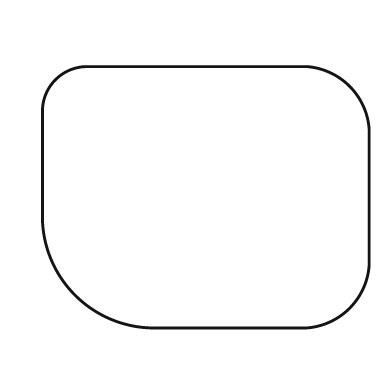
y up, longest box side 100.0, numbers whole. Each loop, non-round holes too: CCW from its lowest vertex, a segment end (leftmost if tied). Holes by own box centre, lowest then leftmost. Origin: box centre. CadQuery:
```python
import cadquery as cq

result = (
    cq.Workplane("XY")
    .moveTo(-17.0, -40.0)
    .lineTo(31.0, -40.0)
    .threePointArc((44.0, -34.0), (50.0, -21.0))
    .lineTo(50.0, 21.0)
    .threePointArc((44.0, 34.0), (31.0, 40.0))
    .lineTo(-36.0, 40.0)
    .threePointArc((-46.0, 36.0), (-50.0, 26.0))
    .lineTo(-50.0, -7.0)
    .threePointArc((-40.0, -30.0), (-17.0, -40.0))
    .close()
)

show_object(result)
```